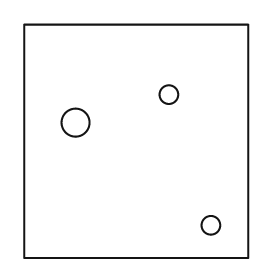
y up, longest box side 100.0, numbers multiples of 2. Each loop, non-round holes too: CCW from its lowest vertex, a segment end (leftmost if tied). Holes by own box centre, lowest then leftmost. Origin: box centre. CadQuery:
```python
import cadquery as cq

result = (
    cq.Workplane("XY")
    .moveTo(-48.0, -50.0)
    .lineTo(48.0, -50.0)
    .lineTo(48.0, 50.0)
    .lineTo(-48.0, 50.0)
    .close()
    .moveTo(32.0, -36.0)
    .circle(4.0)
    .moveTo(-26.0, 8.0)
    .circle(6.0)
    .moveTo(14.0, 20.0)
    .circle(4.0)
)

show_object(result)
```